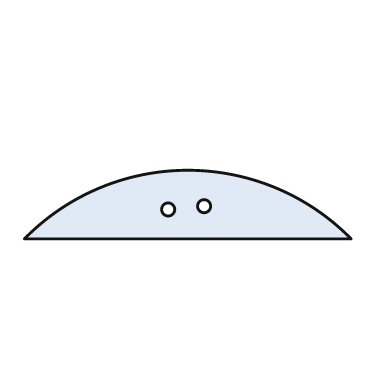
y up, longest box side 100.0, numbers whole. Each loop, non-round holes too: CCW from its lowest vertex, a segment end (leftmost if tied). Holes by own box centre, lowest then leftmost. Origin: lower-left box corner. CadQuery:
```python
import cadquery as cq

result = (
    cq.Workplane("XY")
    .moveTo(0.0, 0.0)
    .lineTo(100.0, 0.0)
    .threePointArc((50.0, 21.0), (0.0, 0.0))
    .close()
    .moveTo(44.0, 9.0)
    .circle(2.0)
    .moveTo(55.0, 10.0)
    .circle(2.0)
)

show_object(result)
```